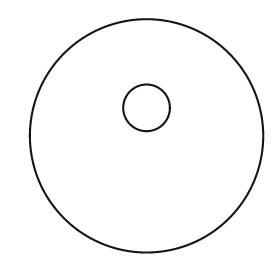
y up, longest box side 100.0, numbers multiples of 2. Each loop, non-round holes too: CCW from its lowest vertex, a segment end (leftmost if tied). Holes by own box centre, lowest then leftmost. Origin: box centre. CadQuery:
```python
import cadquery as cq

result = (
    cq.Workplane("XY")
    .moveTo(0.0, 0.0)
    .circle(50.0)
    .moveTo(0.0, 12.0)
    .circle(10.0)
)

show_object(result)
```